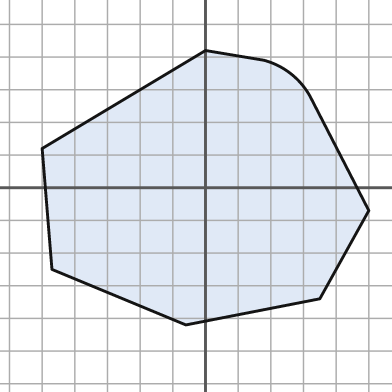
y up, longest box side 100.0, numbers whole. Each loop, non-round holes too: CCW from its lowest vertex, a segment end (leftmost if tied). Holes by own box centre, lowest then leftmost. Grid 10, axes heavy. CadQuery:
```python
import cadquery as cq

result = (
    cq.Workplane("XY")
    .moveTo(-6.0, -42.0)
    .lineTo(35.0, -34.0)
    .lineTo(50.0, -7.0)
    .lineTo(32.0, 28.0)
    .threePointArc((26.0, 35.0), (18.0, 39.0))
    .lineTo(0.0, 42.0)
    .lineTo(-50.0, 12.0)
    .lineTo(-47.0, -25.0)
    .close()
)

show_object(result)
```